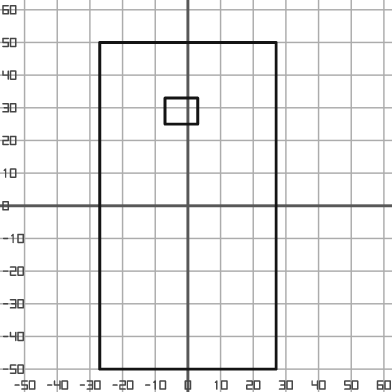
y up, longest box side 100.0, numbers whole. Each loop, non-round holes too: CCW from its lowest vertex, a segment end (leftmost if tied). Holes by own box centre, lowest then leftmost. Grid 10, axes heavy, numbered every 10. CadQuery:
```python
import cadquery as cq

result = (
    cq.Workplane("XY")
    .moveTo(-27.0, -50.0)
    .lineTo(27.0, -50.0)
    .lineTo(27.0, 50.0)
    .lineTo(-27.0, 50.0)
    .close()
    .moveTo(-7.0, 25.0)
    .lineTo(3.0, 25.0)
    .lineTo(3.0, 33.0)
    .lineTo(-7.0, 33.0)
    .close()
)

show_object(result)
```